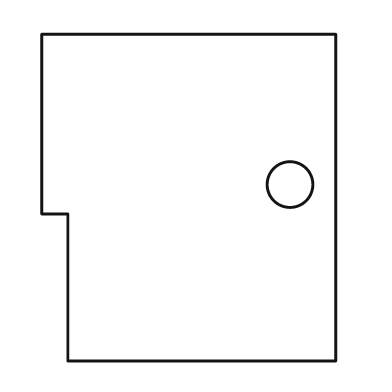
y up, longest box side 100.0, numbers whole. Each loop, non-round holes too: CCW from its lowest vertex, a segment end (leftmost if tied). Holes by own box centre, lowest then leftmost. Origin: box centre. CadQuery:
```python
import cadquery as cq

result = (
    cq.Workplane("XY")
    .moveTo(-37.0, -50.0)
    .lineTo(45.0, -50.0)
    .lineTo(45.0, 50.0)
    .lineTo(-45.0, 50.0)
    .lineTo(-45.0, -5.0)
    .lineTo(-37.0, -5.0)
    .close()
    .moveTo(31.0, 4.0)
    .circle(7.0)
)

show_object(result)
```